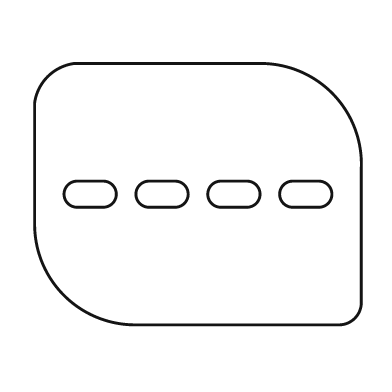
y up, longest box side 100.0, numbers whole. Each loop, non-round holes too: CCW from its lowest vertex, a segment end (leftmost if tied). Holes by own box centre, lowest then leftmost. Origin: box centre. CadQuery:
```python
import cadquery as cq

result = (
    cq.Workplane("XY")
    .moveTo(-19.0, -40.0)
    .lineTo(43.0, -40.0)
    .threePointArc((48.0, -38.0), (50.0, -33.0))
    .lineTo(50.0, 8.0)
    .threePointArc((41.0, 31.0), (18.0, 40.0))
    .lineTo(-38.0, 40.0)
    .threePointArc((-46.0, 36.0), (-50.0, 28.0))
    .lineTo(-50.0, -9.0)
    .threePointArc((-41.0, -31.0), (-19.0, -40.0))
    .close()
    .moveTo(-37.0, -4.0)
    .lineTo(-29.0, -4.0)
    .threePointArc((-25.0, 0.0), (-29.0, 4.0))
    .lineTo(-37.0, 4.0)
    .threePointArc((-41.0, 0.0), (-37.0, -4.0))
    .close()
    .moveTo(-15.0, -4.0)
    .lineTo(-7.0, -4.0)
    .threePointArc((-3.0, 0.0), (-7.0, 4.0))
    .lineTo(-15.0, 4.0)
    .threePointArc((-19.0, 0.0), (-15.0, -4.0))
    .close()
    .moveTo(7.0, -4.0)
    .lineTo(15.0, -4.0)
    .threePointArc((19.0, 0.0), (15.0, 4.0))
    .lineTo(7.0, 4.0)
    .threePointArc((3.0, 0.0), (7.0, -4.0))
    .close()
    .moveTo(29.0, -4.0)
    .lineTo(37.0, -4.0)
    .threePointArc((41.0, 0.0), (37.0, 4.0))
    .lineTo(29.0, 4.0)
    .threePointArc((25.0, 0.0), (29.0, -4.0))
    .close()
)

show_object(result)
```